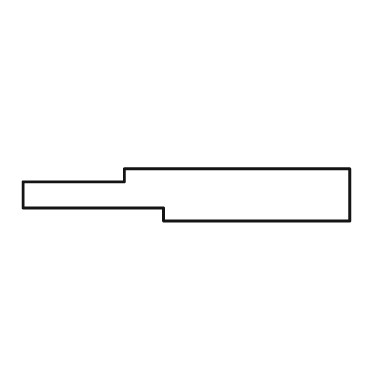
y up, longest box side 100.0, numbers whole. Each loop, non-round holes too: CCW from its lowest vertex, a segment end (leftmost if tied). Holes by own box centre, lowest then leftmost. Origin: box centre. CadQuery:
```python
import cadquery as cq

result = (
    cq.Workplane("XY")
    .moveTo(-7.0, -8.0)
    .lineTo(50.0, -8.0)
    .lineTo(50.0, 8.0)
    .lineTo(-19.0, 8.0)
    .lineTo(-19.0, 4.0)
    .lineTo(-50.0, 4.0)
    .lineTo(-50.0, -4.0)
    .lineTo(-7.0, -4.0)
    .close()
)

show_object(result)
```